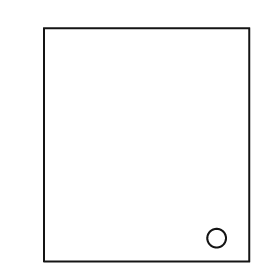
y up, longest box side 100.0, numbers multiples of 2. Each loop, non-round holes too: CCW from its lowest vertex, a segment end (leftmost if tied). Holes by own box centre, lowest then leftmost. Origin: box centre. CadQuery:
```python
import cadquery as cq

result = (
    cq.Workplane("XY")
    .moveTo(-44.0, -50.0)
    .lineTo(44.0, -50.0)
    .lineTo(44.0, 50.0)
    .lineTo(-44.0, 50.0)
    .close()
    .moveTo(30.0, -40.0)
    .circle(4.0)
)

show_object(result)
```